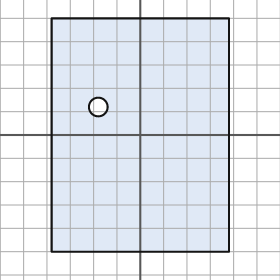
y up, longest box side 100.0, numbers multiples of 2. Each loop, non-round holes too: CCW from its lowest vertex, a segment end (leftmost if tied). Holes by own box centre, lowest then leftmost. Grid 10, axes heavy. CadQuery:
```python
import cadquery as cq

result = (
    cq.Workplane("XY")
    .moveTo(-38.0, -50.0)
    .lineTo(38.0, -50.0)
    .lineTo(38.0, 50.0)
    .lineTo(-38.0, 50.0)
    .close()
    .moveTo(-18.0, 12.0)
    .circle(4.0)
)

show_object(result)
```